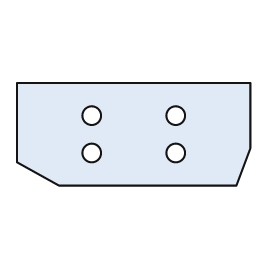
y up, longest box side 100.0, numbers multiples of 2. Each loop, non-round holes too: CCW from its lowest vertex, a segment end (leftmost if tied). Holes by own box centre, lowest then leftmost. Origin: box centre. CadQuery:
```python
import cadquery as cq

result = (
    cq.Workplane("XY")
    .moveTo(-32.0, -22.0)
    .lineTo(44.0, -22.0)
    .lineTo(50.0, -6.0)
    .lineTo(50.0, 22.0)
    .lineTo(-50.0, 22.0)
    .lineTo(-50.0, -12.0)
    .close()
    .moveTo(-18.0, -8.0)
    .circle(4.0)
    .moveTo(18.0, -8.0)
    .circle(4.0)
    .moveTo(-18.0, 8.0)
    .circle(4.0)
    .moveTo(18.0, 8.0)
    .circle(4.0)
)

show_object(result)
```